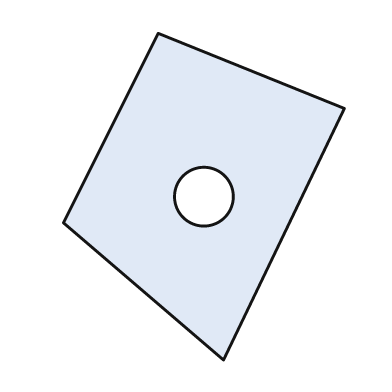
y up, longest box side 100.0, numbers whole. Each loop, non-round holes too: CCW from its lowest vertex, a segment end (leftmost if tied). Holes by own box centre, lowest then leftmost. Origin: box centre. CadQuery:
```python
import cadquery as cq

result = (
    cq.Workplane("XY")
    .moveTo(6.0, -50.0)
    .lineTo(43.0, 27.0)
    .lineTo(-14.0, 50.0)
    .lineTo(-43.0, -8.0)
    .close()
    .moveTo(0.0, 0.0)
    .circle(9.0)
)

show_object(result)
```